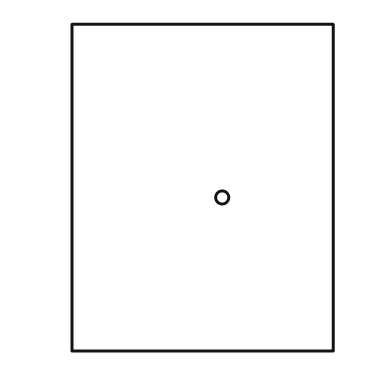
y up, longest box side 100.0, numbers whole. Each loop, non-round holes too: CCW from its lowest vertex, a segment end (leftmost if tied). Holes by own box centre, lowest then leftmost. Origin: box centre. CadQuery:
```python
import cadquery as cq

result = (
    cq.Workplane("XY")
    .moveTo(-40.0, -50.0)
    .lineTo(40.0, -50.0)
    .lineTo(40.0, 50.0)
    .lineTo(-40.0, 50.0)
    .close()
    .moveTo(6.0, -3.0)
    .circle(2.0)
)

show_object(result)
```